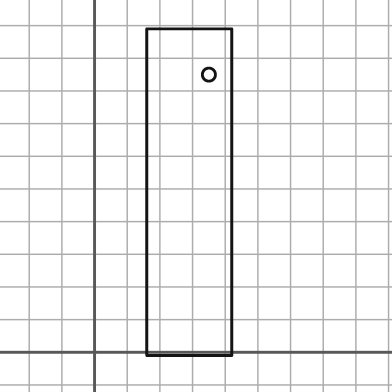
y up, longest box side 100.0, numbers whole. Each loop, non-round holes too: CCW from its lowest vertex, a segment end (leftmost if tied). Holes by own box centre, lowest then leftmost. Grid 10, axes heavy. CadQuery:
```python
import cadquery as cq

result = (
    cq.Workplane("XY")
    .moveTo(16.0, -1.0)
    .lineTo(42.0, -1.0)
    .lineTo(42.0, 99.0)
    .lineTo(16.0, 99.0)
    .close()
    .moveTo(35.0, 85.0)
    .circle(2.0)
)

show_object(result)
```